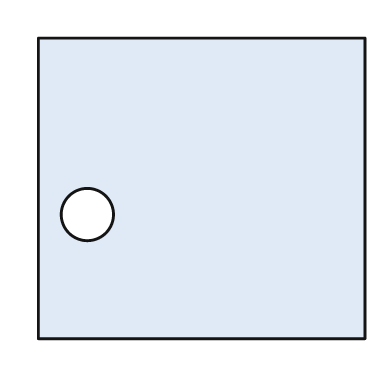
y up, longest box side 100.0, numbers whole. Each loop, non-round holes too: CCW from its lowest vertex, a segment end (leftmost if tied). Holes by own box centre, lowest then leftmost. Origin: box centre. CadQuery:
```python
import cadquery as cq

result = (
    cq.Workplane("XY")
    .moveTo(-50.0, -46.0)
    .lineTo(50.0, -46.0)
    .lineTo(50.0, 46.0)
    .lineTo(-50.0, 46.0)
    .close()
    .moveTo(-35.0, -8.0)
    .circle(8.0)
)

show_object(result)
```